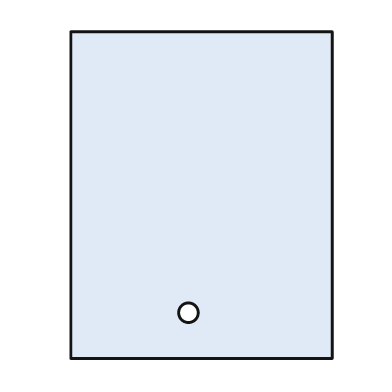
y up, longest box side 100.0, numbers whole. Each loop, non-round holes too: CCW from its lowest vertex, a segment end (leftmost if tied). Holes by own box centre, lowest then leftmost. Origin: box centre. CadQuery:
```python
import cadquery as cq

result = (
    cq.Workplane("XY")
    .moveTo(-40.0, -50.0)
    .lineTo(40.0, -50.0)
    .lineTo(40.0, 50.0)
    .lineTo(-40.0, 50.0)
    .close()
    .moveTo(-4.0, -36.0)
    .circle(3.0)
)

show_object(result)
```